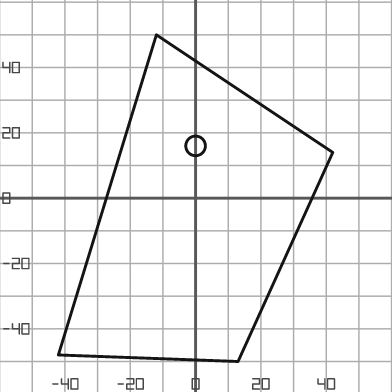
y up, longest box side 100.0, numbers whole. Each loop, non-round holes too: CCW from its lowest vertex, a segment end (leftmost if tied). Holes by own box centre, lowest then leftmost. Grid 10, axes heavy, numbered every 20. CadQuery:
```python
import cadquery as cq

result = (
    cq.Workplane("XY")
    .moveTo(13.0, -50.0)
    .lineTo(42.0, 14.0)
    .lineTo(-12.0, 50.0)
    .lineTo(-42.0, -48.0)
    .close()
    .moveTo(0.0, 16.0)
    .circle(3.0)
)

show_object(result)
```